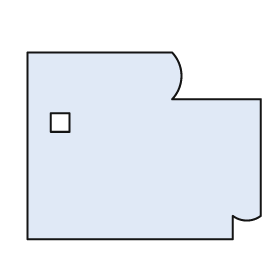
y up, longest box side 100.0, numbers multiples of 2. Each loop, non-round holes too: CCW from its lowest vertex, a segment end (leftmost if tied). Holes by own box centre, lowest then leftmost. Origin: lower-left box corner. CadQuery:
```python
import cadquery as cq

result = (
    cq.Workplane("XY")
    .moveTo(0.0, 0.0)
    .lineTo(88.0, 0.0)
    .lineTo(88.0, 10.0)
    .threePointArc((94.0, 8.0), (100.0, 10.0))
    .lineTo(100.0, 60.0)
    .lineTo(62.0, 60.0)
    .threePointArc((66.0, 70.0), (62.0, 80.0))
    .lineTo(0.0, 80.0)
    .close()
    .moveTo(10.0, 46.0)
    .lineTo(18.0, 46.0)
    .lineTo(18.0, 54.0)
    .lineTo(10.0, 54.0)
    .close()
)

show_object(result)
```